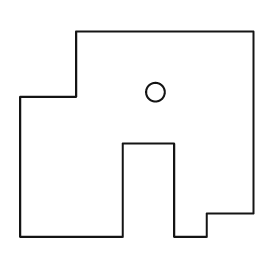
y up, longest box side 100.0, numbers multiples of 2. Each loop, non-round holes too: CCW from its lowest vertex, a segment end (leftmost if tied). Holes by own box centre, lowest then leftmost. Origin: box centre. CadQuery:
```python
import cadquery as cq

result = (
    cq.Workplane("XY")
    .moveTo(-50.0, -44.0)
    .lineTo(-6.0, -44.0)
    .lineTo(-6.0, -4.0)
    .lineTo(16.0, -4.0)
    .lineTo(16.0, -44.0)
    .lineTo(30.0, -44.0)
    .lineTo(30.0, -34.0)
    .lineTo(50.0, -34.0)
    .lineTo(50.0, 44.0)
    .lineTo(-26.0, 44.0)
    .lineTo(-26.0, 16.0)
    .lineTo(-50.0, 16.0)
    .close()
    .moveTo(8.0, 18.0)
    .circle(4.0)
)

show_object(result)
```